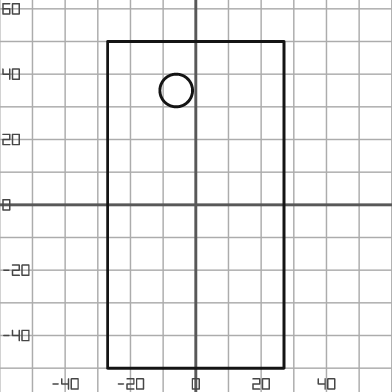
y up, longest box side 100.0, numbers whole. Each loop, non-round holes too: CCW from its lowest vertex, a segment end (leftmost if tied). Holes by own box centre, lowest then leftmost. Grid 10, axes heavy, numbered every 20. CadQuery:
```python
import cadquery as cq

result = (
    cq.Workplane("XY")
    .moveTo(-27.0, -50.0)
    .lineTo(27.0, -50.0)
    .lineTo(27.0, 50.0)
    .lineTo(-27.0, 50.0)
    .close()
    .moveTo(-6.0, 35.0)
    .circle(5.0)
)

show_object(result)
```